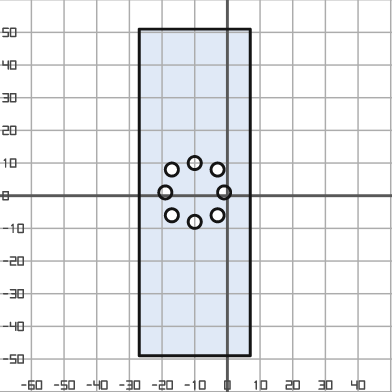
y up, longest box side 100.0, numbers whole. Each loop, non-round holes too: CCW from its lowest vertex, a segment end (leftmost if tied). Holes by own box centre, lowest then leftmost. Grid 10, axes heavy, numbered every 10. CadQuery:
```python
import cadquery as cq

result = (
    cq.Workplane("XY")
    .moveTo(-27.0, -49.0)
    .lineTo(7.0, -49.0)
    .lineTo(7.0, 51.0)
    .lineTo(-27.0, 51.0)
    .close()
    .moveTo(-10.0, -8.0)
    .circle(2.0)
    .moveTo(-17.0, -6.0)
    .circle(2.0)
    .moveTo(-3.0, -6.0)
    .circle(2.0)
    .moveTo(-19.0, 1.0)
    .circle(2.0)
    .moveTo(-1.0, 1.0)
    .circle(2.0)
    .moveTo(-17.0, 8.0)
    .circle(2.0)
    .moveTo(-3.0, 8.0)
    .circle(2.0)
    .moveTo(-10.0, 10.0)
    .circle(2.0)
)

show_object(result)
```